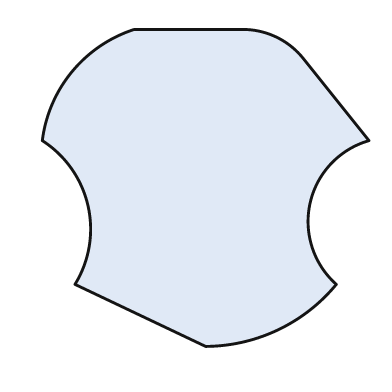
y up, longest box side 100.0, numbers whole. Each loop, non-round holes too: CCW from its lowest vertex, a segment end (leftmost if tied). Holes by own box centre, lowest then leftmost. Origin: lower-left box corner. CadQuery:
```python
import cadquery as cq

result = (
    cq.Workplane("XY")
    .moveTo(50.0, 0.0)
    .threePointArc((72.0, 5.0), (90.0, 19.0))
    .threePointArc((82.0, 44.0), (100.0, 63.0))
    .lineTo(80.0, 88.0)
    .threePointArc((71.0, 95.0), (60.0, 97.0))
    .lineTo(28.0, 97.0)
    .threePointArc((9.0, 84.0), (0.0, 63.0))
    .threePointArc((14.0, 43.0), (10.0, 19.0))
    .close()
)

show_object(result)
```